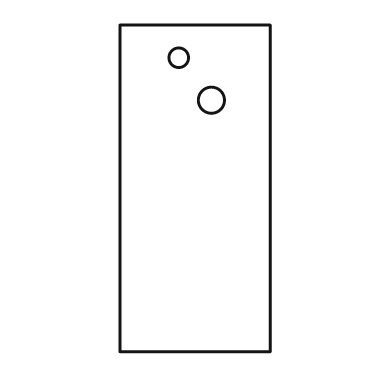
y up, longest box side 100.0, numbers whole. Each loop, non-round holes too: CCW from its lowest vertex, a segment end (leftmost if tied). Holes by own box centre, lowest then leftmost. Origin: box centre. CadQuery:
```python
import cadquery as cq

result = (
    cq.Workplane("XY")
    .moveTo(-23.0, -50.0)
    .lineTo(23.0, -50.0)
    .lineTo(23.0, 50.0)
    .lineTo(-23.0, 50.0)
    .close()
    .moveTo(5.0, 27.0)
    .circle(4.0)
    .moveTo(-5.0, 40.0)
    .circle(3.0)
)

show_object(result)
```